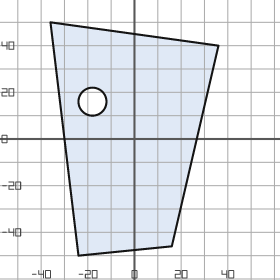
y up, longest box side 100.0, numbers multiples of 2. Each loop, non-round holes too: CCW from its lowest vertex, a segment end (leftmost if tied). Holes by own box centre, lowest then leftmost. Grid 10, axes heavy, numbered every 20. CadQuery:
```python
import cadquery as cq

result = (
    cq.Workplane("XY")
    .moveTo(-24.0, -50.0)
    .lineTo(16.0, -46.0)
    .lineTo(36.0, 40.0)
    .lineTo(-36.0, 50.0)
    .close()
    .moveTo(-18.0, 16.0)
    .circle(6.0)
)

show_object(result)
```